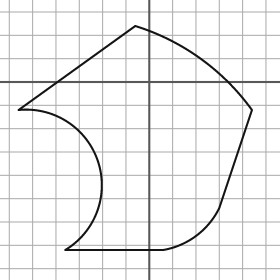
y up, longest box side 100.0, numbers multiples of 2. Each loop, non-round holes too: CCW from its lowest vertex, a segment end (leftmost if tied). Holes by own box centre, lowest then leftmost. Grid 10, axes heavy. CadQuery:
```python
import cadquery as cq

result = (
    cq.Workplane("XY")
    .moveTo(-36.0, -72.0)
    .lineTo(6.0, -72.0)
    .threePointArc((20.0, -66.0), (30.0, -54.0))
    .lineTo(44.0, -12.0)
    .threePointArc((22.0, 10.0), (-6.0, 24.0))
    .lineTo(-56.0, -12.0)
    .threePointArc((-22.0, -34.0), (-36.0, -72.0))
    .close()
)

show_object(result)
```